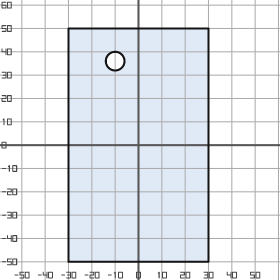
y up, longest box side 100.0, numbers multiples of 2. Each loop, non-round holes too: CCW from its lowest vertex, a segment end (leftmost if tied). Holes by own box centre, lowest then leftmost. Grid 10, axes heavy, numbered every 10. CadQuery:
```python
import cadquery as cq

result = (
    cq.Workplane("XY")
    .moveTo(-30.0, -50.0)
    .lineTo(30.0, -50.0)
    .lineTo(30.0, 50.0)
    .lineTo(-30.0, 50.0)
    .close()
    .moveTo(-10.0, 36.0)
    .circle(4.0)
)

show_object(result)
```